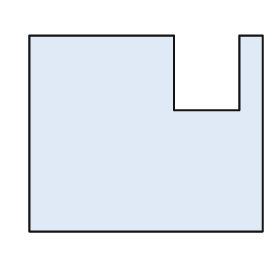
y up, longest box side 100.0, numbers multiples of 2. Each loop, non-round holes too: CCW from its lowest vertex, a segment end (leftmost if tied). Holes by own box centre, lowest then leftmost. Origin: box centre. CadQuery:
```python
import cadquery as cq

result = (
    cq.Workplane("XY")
    .moveTo(-50.0, -42.0)
    .lineTo(50.0, -42.0)
    .lineTo(50.0, 42.0)
    .lineTo(40.0, 42.0)
    .lineTo(40.0, 10.0)
    .lineTo(12.0, 10.0)
    .lineTo(12.0, 42.0)
    .lineTo(-50.0, 42.0)
    .close()
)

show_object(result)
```